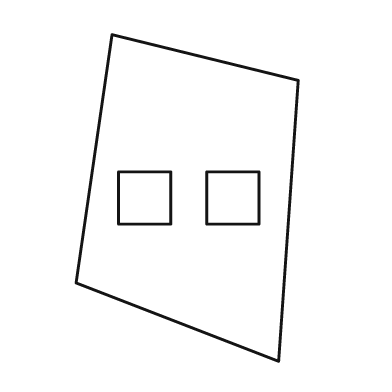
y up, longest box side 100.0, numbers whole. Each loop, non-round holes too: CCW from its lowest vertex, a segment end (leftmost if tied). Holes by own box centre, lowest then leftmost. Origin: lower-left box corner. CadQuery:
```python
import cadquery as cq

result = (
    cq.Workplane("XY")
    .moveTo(62.0, 0.0)
    .lineTo(68.0, 86.0)
    .lineTo(11.0, 100.0)
    .lineTo(0.0, 24.0)
    .close()
    .moveTo(13.0, 42.0)
    .lineTo(29.0, 42.0)
    .lineTo(29.0, 58.0)
    .lineTo(13.0, 58.0)
    .close()
    .moveTo(40.0, 42.0)
    .lineTo(56.0, 42.0)
    .lineTo(56.0, 58.0)
    .lineTo(40.0, 58.0)
    .close()
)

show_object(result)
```